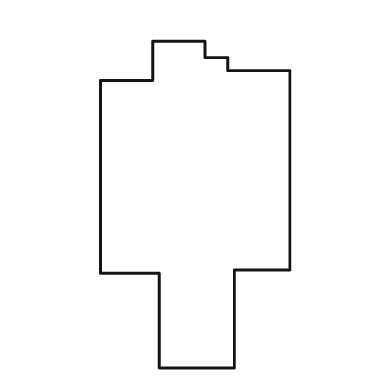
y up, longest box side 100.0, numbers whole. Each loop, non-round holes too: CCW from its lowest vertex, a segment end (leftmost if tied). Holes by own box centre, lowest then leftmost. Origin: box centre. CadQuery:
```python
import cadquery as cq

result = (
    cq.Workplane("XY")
    .moveTo(-11.0, -50.0)
    .lineTo(12.0, -50.0)
    .lineTo(12.0, -20.0)
    .lineTo(29.0, -20.0)
    .lineTo(29.0, 41.0)
    .lineTo(10.0, 41.0)
    .lineTo(10.0, 45.0)
    .lineTo(3.0, 45.0)
    .lineTo(3.0, 50.0)
    .lineTo(-13.0, 50.0)
    .lineTo(-13.0, 38.0)
    .lineTo(-29.0, 38.0)
    .lineTo(-29.0, -21.0)
    .lineTo(-11.0, -21.0)
    .close()
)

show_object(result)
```